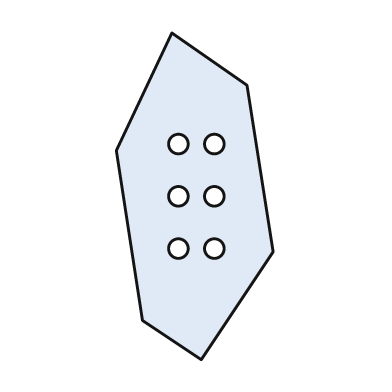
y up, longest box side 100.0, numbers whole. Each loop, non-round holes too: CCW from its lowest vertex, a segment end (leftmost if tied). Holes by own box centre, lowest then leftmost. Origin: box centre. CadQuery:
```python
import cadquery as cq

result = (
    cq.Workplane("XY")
    .moveTo(2.0, -50.0)
    .lineTo(24.0, -17.0)
    .lineTo(16.0, 34.0)
    .lineTo(-7.0, 50.0)
    .lineTo(-24.0, 14.0)
    .lineTo(-16.0, -38.0)
    .close()
    .moveTo(-5.0, -16.0)
    .circle(3.0)
    .moveTo(6.0, -16.0)
    .circle(3.0)
    .moveTo(-5.0, 0.0)
    .circle(3.0)
    .moveTo(6.0, 0.0)
    .circle(3.0)
    .moveTo(-5.0, 16.0)
    .circle(3.0)
    .moveTo(6.0, 16.0)
    .circle(3.0)
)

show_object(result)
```